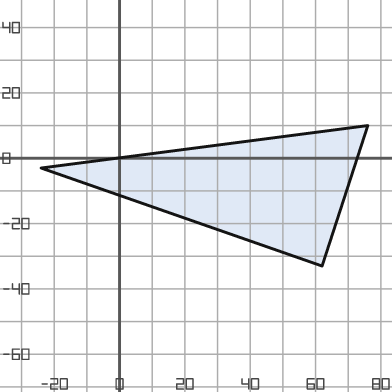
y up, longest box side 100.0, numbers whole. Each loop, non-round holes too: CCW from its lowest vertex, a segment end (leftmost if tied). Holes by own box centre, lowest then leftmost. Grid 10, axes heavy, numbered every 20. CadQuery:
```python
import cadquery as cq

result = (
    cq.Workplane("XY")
    .moveTo(62.0, -33.0)
    .lineTo(76.0, 10.0)
    .lineTo(-24.0, -3.0)
    .close()
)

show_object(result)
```